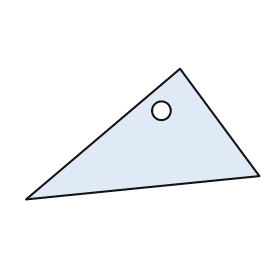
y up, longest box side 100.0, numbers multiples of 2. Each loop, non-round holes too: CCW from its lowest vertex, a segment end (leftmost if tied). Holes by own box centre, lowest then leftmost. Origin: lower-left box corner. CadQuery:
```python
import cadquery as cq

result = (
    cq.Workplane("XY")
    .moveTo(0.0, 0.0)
    .lineTo(100.0, 10.0)
    .lineTo(66.0, 56.0)
    .close()
    .moveTo(58.0, 38.0)
    .circle(4.0)
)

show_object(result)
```